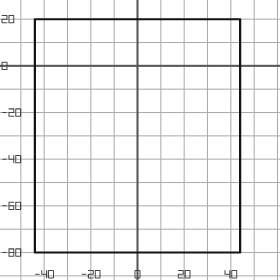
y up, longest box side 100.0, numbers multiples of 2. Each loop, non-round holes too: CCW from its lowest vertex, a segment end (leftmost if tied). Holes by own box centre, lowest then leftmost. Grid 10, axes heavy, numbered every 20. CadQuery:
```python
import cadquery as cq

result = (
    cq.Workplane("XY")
    .moveTo(-44.0, -80.0)
    .lineTo(44.0, -80.0)
    .lineTo(44.0, 20.0)
    .lineTo(-44.0, 20.0)
    .close()
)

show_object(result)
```